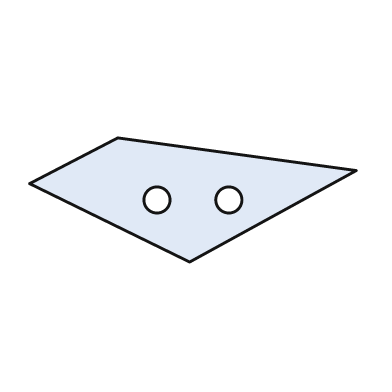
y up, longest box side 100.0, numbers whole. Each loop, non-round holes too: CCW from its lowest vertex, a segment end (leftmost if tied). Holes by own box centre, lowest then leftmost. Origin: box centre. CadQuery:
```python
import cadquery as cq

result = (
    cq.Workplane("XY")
    .moveTo(-1.0, -19.0)
    .lineTo(50.0, 9.0)
    .lineTo(-23.0, 19.0)
    .lineTo(-50.0, 5.0)
    .close()
    .moveTo(-11.0, 0.0)
    .circle(4.0)
    .moveTo(11.0, 0.0)
    .circle(4.0)
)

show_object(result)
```